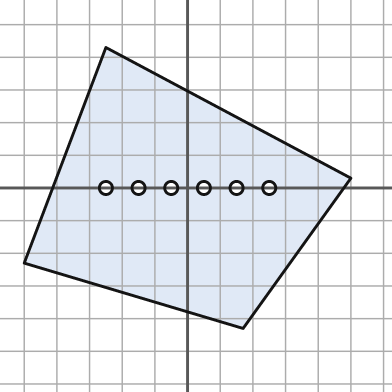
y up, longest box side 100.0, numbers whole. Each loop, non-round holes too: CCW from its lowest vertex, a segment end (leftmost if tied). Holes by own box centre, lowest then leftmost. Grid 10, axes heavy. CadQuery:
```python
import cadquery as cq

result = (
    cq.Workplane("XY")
    .moveTo(17.0, -43.0)
    .lineTo(50.0, 3.0)
    .lineTo(-25.0, 43.0)
    .lineTo(-50.0, -23.0)
    .close()
    .moveTo(-25.0, 0.0)
    .circle(2.0)
    .moveTo(-15.0, 0.0)
    .circle(2.0)
    .moveTo(-5.0, 0.0)
    .circle(2.0)
    .moveTo(5.0, 0.0)
    .circle(2.0)
    .moveTo(15.0, 0.0)
    .circle(2.0)
    .moveTo(25.0, 0.0)
    .circle(2.0)
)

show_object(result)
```